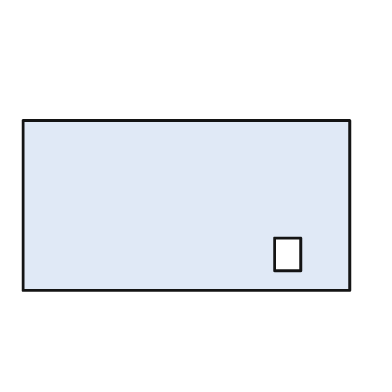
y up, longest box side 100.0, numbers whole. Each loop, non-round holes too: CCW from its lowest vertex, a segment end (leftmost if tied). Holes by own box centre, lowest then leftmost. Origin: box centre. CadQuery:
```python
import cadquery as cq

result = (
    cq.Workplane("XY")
    .moveTo(-50.0, -26.0)
    .lineTo(50.0, -26.0)
    .lineTo(50.0, 26.0)
    .lineTo(-50.0, 26.0)
    .close()
    .moveTo(27.0, -20.0)
    .lineTo(35.0, -20.0)
    .lineTo(35.0, -10.0)
    .lineTo(27.0, -10.0)
    .close()
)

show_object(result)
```